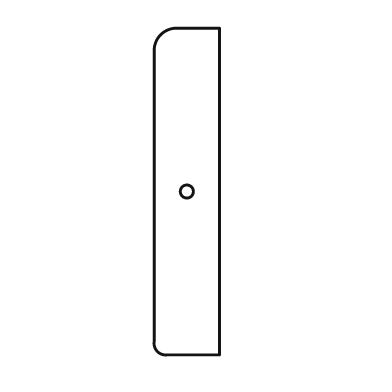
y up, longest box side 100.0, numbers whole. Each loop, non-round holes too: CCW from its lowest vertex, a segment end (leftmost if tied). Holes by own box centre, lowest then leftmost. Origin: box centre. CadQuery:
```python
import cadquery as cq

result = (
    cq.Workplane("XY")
    .moveTo(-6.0, -50.0)
    .lineTo(10.0, -50.0)
    .lineTo(10.0, 50.0)
    .lineTo(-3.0, 50.0)
    .threePointArc((-8.0, 48.0), (-10.0, 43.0))
    .lineTo(-10.0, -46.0)
    .threePointArc((-9.0, -49.0), (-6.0, -50.0))
    .close()
    .moveTo(0.0, 0.0)
    .circle(2.0)
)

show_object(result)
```